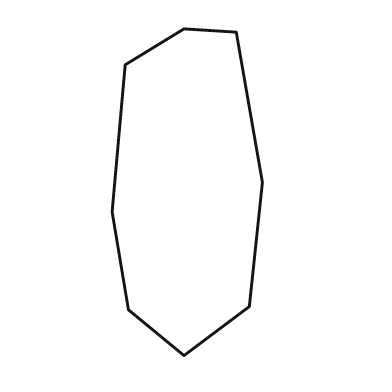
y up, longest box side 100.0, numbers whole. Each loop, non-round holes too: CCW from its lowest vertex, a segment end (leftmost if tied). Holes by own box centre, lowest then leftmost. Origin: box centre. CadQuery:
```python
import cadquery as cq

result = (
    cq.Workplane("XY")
    .moveTo(-1.0, -50.0)
    .lineTo(19.0, -35.0)
    .lineTo(23.0, 3.0)
    .lineTo(15.0, 49.0)
    .lineTo(-1.0, 50.0)
    .lineTo(-19.0, 39.0)
    .lineTo(-23.0, -6.0)
    .lineTo(-18.0, -36.0)
    .close()
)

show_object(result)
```